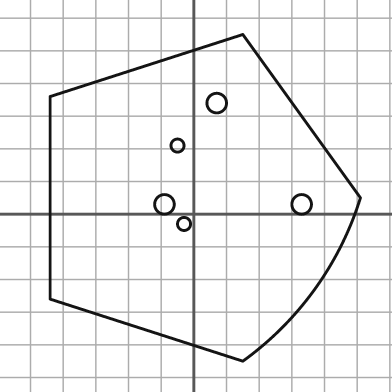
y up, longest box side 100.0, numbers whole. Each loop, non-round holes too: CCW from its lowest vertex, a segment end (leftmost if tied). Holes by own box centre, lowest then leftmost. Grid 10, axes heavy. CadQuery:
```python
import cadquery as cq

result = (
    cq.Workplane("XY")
    .moveTo(15.0, -45.0)
    .threePointArc((37.0, -23.0), (51.0, 5.0))
    .lineTo(15.0, 55.0)
    .lineTo(-44.0, 36.0)
    .lineTo(-44.0, -26.0)
    .close()
    .moveTo(-3.0, -3.0)
    .circle(2.0)
    .moveTo(-9.0, 3.0)
    .circle(3.0)
    .moveTo(33.0, 3.0)
    .circle(3.0)
    .moveTo(-5.0, 21.0)
    .circle(2.0)
    .moveTo(7.0, 34.0)
    .circle(3.0)
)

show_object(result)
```